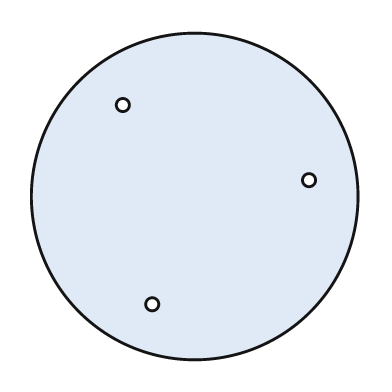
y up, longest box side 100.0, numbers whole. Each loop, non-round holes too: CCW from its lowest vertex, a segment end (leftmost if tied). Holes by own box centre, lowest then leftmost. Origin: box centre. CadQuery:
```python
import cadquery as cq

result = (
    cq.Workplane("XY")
    .moveTo(0.0, 0.0)
    .circle(50.0)
    .moveTo(-13.0, -33.0)
    .circle(2.0)
    .moveTo(35.0, 5.0)
    .circle(2.0)
    .moveTo(-22.0, 28.0)
    .circle(2.0)
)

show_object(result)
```